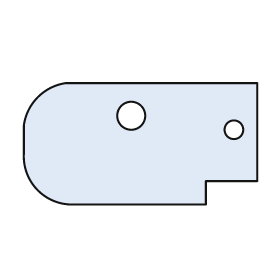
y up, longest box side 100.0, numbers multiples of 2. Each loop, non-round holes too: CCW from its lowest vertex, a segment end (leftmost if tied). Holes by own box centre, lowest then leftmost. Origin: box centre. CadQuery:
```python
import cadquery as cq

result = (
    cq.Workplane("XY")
    .moveTo(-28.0, -26.0)
    .lineTo(28.0, -26.0)
    .lineTo(28.0, -16.0)
    .lineTo(50.0, -16.0)
    .lineTo(50.0, 26.0)
    .lineTo(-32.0, 26.0)
    .threePointArc((-44.0, 20.0), (-50.0, 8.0))
    .lineTo(-50.0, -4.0)
    .threePointArc((-44.0, -20.0), (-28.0, -26.0))
    .close()
    .moveTo(40.0, 6.0)
    .circle(4.0)
    .moveTo(-4.0, 12.0)
    .circle(6.0)
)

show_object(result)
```